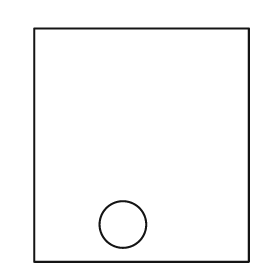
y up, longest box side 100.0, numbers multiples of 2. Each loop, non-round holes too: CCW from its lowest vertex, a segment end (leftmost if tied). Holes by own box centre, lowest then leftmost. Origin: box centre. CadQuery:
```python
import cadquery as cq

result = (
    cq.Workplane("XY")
    .moveTo(-46.0, -50.0)
    .lineTo(46.0, -50.0)
    .lineTo(46.0, 50.0)
    .lineTo(-46.0, 50.0)
    .close()
    .moveTo(-8.0, -34.0)
    .circle(10.0)
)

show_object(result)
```